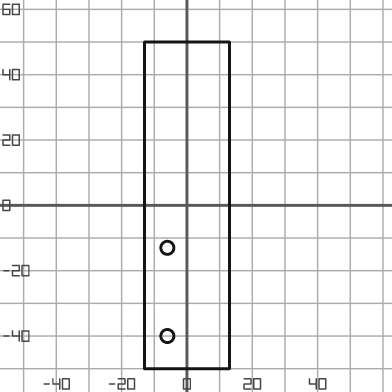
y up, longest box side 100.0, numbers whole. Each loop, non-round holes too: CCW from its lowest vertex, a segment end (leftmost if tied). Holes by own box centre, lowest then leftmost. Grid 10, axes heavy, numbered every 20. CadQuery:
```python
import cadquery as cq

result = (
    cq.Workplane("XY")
    .moveTo(-13.0, -50.0)
    .lineTo(13.0, -50.0)
    .lineTo(13.0, 50.0)
    .lineTo(-13.0, 50.0)
    .close()
    .moveTo(-6.0, -40.0)
    .circle(2.0)
    .moveTo(-6.0, -13.0)
    .circle(2.0)
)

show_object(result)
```